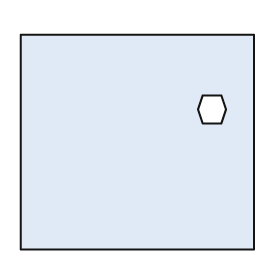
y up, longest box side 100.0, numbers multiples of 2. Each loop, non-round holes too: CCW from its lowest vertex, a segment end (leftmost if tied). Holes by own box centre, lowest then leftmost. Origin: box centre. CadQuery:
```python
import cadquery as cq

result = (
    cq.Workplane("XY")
    .moveTo(-50.0, -46.0)
    .lineTo(50.0, -46.0)
    .lineTo(50.0, 46.0)
    .lineTo(-50.0, 46.0)
    .close()
    .moveTo(28.0, 8.0)
    .lineTo(36.0, 8.0)
    .lineTo(38.0, 14.0)
    .lineTo(36.0, 20.0)
    .lineTo(28.0, 20.0)
    .lineTo(26.0, 14.0)
    .close()
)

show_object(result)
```